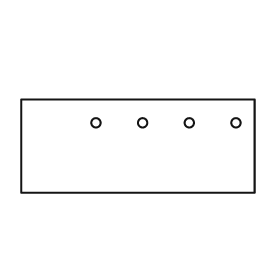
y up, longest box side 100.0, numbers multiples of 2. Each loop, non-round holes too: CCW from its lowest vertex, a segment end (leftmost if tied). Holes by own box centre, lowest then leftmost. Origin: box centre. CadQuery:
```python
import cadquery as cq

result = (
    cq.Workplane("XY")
    .moveTo(-50.0, -20.0)
    .lineTo(50.0, -20.0)
    .lineTo(50.0, 20.0)
    .lineTo(-50.0, 20.0)
    .close()
    .moveTo(-18.0, 10.0)
    .circle(2.0)
    .moveTo(2.0, 10.0)
    .circle(2.0)
    .moveTo(22.0, 10.0)
    .circle(2.0)
    .moveTo(42.0, 10.0)
    .circle(2.0)
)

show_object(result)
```